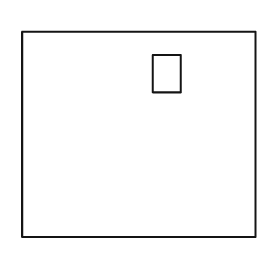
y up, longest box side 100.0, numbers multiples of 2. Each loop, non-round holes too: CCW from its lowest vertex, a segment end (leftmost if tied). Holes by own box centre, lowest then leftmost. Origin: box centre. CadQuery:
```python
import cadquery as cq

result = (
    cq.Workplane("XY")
    .moveTo(-50.0, -44.0)
    .lineTo(50.0, -44.0)
    .lineTo(50.0, 44.0)
    .lineTo(-50.0, 44.0)
    .close()
    .moveTo(6.0, 18.0)
    .lineTo(18.0, 18.0)
    .lineTo(18.0, 34.0)
    .lineTo(6.0, 34.0)
    .close()
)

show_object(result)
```